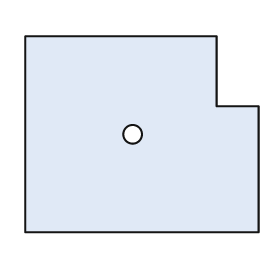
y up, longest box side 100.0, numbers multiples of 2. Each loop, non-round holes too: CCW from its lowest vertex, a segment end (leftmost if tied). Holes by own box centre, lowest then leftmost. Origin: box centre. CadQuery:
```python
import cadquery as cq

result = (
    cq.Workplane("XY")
    .moveTo(-50.0, -42.0)
    .lineTo(50.0, -42.0)
    .lineTo(50.0, 12.0)
    .lineTo(32.0, 12.0)
    .lineTo(32.0, 42.0)
    .lineTo(-50.0, 42.0)
    .close()
    .moveTo(-4.0, 0.0)
    .circle(4.0)
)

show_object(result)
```